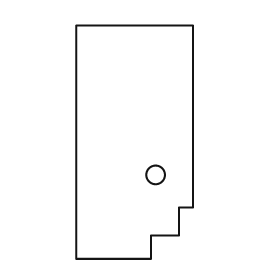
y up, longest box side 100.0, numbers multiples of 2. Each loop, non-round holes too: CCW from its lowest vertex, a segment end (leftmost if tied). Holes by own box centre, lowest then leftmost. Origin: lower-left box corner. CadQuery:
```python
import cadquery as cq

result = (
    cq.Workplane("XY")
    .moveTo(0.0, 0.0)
    .lineTo(32.0, 0.0)
    .lineTo(32.0, 10.0)
    .lineTo(44.0, 10.0)
    .lineTo(44.0, 22.0)
    .lineTo(50.0, 22.0)
    .lineTo(50.0, 100.0)
    .lineTo(0.0, 100.0)
    .close()
    .moveTo(34.0, 36.0)
    .circle(4.0)
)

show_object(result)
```